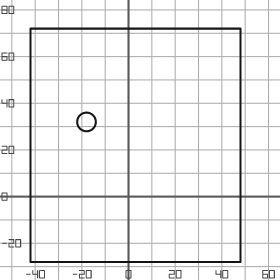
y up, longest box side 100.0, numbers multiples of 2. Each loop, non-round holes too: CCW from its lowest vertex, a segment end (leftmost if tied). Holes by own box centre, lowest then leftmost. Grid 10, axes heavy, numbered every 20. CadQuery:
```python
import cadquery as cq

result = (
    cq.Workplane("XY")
    .moveTo(-42.0, -28.0)
    .lineTo(48.0, -28.0)
    .lineTo(48.0, 72.0)
    .lineTo(-42.0, 72.0)
    .close()
    .moveTo(-18.0, 32.0)
    .circle(4.0)
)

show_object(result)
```